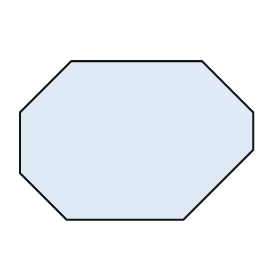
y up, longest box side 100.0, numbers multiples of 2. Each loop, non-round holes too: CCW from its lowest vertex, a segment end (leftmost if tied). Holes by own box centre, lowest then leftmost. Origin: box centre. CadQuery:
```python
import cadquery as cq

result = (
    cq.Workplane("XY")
    .moveTo(-30.0, -34.0)
    .lineTo(20.0, -34.0)
    .lineTo(50.0, -4.0)
    .lineTo(50.0, 12.0)
    .lineTo(28.0, 34.0)
    .lineTo(-28.0, 34.0)
    .lineTo(-50.0, 12.0)
    .lineTo(-50.0, -14.0)
    .close()
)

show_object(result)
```